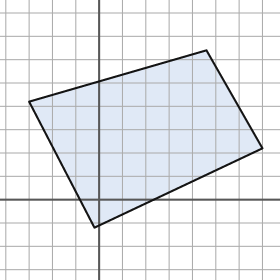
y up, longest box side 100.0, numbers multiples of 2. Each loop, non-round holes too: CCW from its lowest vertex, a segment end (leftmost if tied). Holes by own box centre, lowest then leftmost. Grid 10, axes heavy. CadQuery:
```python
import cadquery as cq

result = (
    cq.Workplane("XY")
    .moveTo(-2.0, -12.0)
    .lineTo(70.0, 22.0)
    .lineTo(46.0, 64.0)
    .lineTo(-30.0, 42.0)
    .close()
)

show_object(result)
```